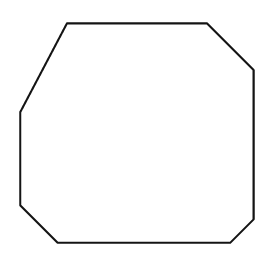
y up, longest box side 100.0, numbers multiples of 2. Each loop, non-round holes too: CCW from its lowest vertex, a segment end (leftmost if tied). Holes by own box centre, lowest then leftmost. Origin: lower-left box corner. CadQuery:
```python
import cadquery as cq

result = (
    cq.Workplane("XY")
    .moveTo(16.0, 0.0)
    .lineTo(90.0, 0.0)
    .lineTo(100.0, 10.0)
    .lineTo(100.0, 74.0)
    .lineTo(80.0, 94.0)
    .lineTo(20.0, 94.0)
    .lineTo(0.0, 56.0)
    .lineTo(0.0, 16.0)
    .close()
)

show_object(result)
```